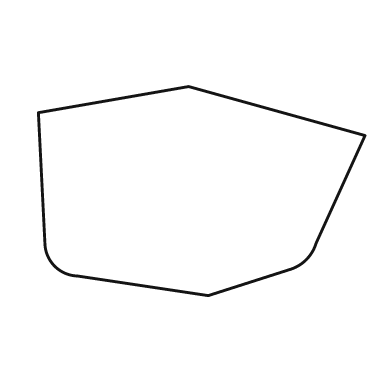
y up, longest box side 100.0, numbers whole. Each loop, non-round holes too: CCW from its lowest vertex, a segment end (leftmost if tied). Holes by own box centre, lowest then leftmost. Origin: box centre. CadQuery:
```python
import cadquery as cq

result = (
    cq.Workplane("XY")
    .moveTo(2.0, -32.0)
    .lineTo(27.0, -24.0)
    .threePointArc((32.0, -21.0), (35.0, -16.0))
    .lineTo(50.0, 17.0)
    .lineTo(-4.0, 32.0)
    .lineTo(-50.0, 24.0)
    .lineTo(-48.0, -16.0)
    .threePointArc((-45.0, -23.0), (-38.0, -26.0))
    .close()
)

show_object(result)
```